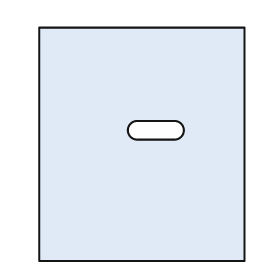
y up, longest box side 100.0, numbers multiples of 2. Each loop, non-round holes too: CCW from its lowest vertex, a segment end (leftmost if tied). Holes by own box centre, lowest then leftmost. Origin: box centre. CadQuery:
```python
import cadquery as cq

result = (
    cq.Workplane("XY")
    .moveTo(-44.0, -50.0)
    .lineTo(44.0, -50.0)
    .lineTo(44.0, 50.0)
    .lineTo(-44.0, 50.0)
    .close()
    .moveTo(-2.0, 2.0)
    .lineTo(14.0, 2.0)
    .threePointArc((18.0, 6.0), (14.0, 10.0))
    .lineTo(-2.0, 10.0)
    .threePointArc((-6.0, 6.0), (-2.0, 2.0))
    .close()
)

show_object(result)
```